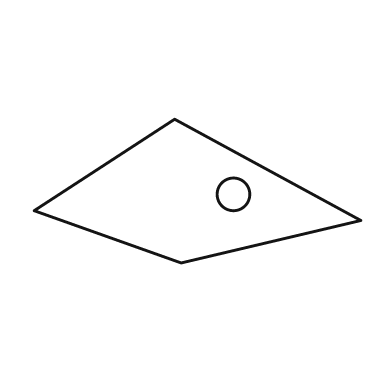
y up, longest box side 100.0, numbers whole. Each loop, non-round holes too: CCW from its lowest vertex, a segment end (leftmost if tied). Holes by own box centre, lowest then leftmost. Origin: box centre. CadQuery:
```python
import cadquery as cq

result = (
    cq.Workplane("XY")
    .moveTo(-5.0, -22.0)
    .lineTo(50.0, -9.0)
    .lineTo(-7.0, 22.0)
    .lineTo(-50.0, -6.0)
    .close()
    .moveTo(11.0, -1.0)
    .circle(5.0)
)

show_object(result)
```